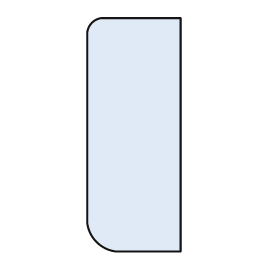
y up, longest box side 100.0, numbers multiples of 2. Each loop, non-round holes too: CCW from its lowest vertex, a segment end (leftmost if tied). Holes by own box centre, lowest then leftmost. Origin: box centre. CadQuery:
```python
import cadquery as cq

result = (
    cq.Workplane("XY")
    .moveTo(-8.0, -50.0)
    .lineTo(20.0, -50.0)
    .lineTo(20.0, 50.0)
    .lineTo(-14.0, 50.0)
    .threePointArc((-18.0, 48.0), (-20.0, 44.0))
    .lineTo(-20.0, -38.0)
    .threePointArc((-16.0, -46.0), (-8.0, -50.0))
    .close()
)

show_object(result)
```